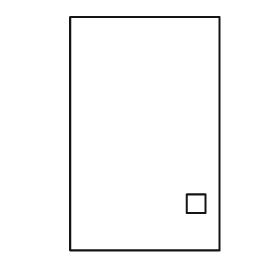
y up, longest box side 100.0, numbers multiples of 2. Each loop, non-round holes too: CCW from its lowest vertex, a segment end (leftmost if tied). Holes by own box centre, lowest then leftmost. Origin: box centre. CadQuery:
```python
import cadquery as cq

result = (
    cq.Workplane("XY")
    .moveTo(-32.0, -50.0)
    .lineTo(32.0, -50.0)
    .lineTo(32.0, 50.0)
    .lineTo(-32.0, 50.0)
    .close()
    .moveTo(18.0, -34.0)
    .lineTo(26.0, -34.0)
    .lineTo(26.0, -26.0)
    .lineTo(18.0, -26.0)
    .close()
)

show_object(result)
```